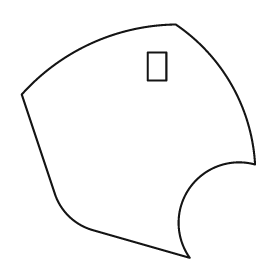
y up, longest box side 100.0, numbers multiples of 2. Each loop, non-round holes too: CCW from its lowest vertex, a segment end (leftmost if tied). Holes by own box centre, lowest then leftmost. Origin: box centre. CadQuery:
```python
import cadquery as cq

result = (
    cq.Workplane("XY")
    .moveTo(22.0, -50.0)
    .threePointArc((22.0, -20.0), (50.0, -10.0))
    .threePointArc((40.0, 24.0), (16.0, 50.0))
    .threePointArc((-20.0, 42.0), (-50.0, 20.0))
    .lineTo(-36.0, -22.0)
    .threePointArc((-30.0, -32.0), (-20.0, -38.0))
    .close()
    .moveTo(4.0, 26.0)
    .lineTo(12.0, 26.0)
    .lineTo(12.0, 38.0)
    .lineTo(4.0, 38.0)
    .close()
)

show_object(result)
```